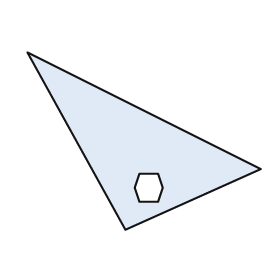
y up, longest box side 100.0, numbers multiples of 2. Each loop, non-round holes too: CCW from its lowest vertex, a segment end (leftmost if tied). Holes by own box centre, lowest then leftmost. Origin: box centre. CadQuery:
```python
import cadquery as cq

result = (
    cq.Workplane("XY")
    .moveTo(-8.0, -38.0)
    .lineTo(50.0, -12.0)
    .lineTo(-50.0, 38.0)
    .close()
    .moveTo(-2.0, -26.0)
    .lineTo(6.0, -26.0)
    .lineTo(8.0, -20.0)
    .lineTo(6.0, -14.0)
    .lineTo(-2.0, -14.0)
    .lineTo(-4.0, -20.0)
    .close()
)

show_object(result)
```